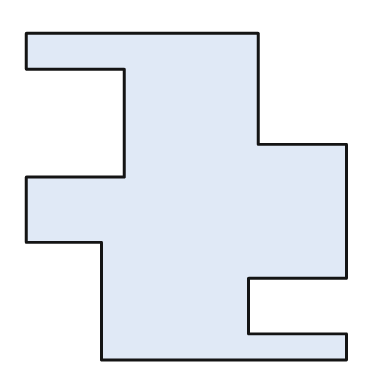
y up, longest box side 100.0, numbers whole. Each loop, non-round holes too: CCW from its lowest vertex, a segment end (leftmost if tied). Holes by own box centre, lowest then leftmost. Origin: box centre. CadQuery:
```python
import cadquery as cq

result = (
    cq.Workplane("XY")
    .moveTo(-26.0, -50.0)
    .lineTo(49.0, -50.0)
    .lineTo(49.0, -42.0)
    .lineTo(19.0, -42.0)
    .lineTo(19.0, -25.0)
    .lineTo(49.0, -25.0)
    .lineTo(49.0, 16.0)
    .lineTo(22.0, 16.0)
    .lineTo(22.0, 50.0)
    .lineTo(-49.0, 50.0)
    .lineTo(-49.0, 39.0)
    .lineTo(-19.0, 39.0)
    .lineTo(-19.0, 6.0)
    .lineTo(-49.0, 6.0)
    .lineTo(-49.0, -14.0)
    .lineTo(-26.0, -14.0)
    .close()
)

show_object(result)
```